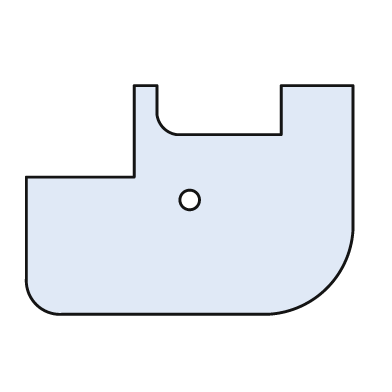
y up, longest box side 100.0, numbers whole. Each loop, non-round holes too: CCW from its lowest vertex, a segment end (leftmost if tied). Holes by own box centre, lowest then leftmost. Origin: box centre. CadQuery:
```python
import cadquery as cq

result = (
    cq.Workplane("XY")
    .moveTo(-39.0, -35.0)
    .lineTo(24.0, -35.0)
    .threePointArc((42.0, -27.0), (50.0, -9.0))
    .lineTo(50.0, 35.0)
    .lineTo(28.0, 35.0)
    .lineTo(28.0, 20.0)
    .lineTo(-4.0, 20.0)
    .threePointArc((-8.0, 22.0), (-10.0, 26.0))
    .lineTo(-10.0, 35.0)
    .lineTo(-17.0, 35.0)
    .lineTo(-17.0, 7.0)
    .lineTo(-50.0, 7.0)
    .lineTo(-50.0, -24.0)
    .threePointArc((-47.0, -32.0), (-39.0, -35.0))
    .close()
    .moveTo(0.0, 0.0)
    .circle(3.0)
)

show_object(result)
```